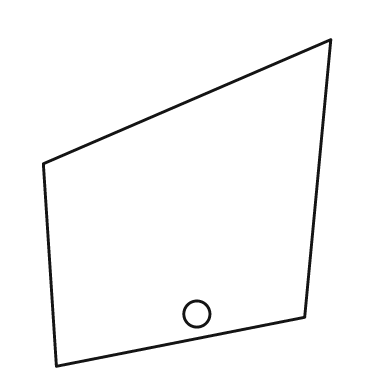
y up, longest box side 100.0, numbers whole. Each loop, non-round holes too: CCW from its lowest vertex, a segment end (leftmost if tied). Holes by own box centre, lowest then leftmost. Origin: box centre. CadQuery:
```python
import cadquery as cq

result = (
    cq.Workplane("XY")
    .moveTo(-40.0, -50.0)
    .lineTo(36.0, -35.0)
    .lineTo(44.0, 50.0)
    .lineTo(-44.0, 12.0)
    .close()
    .moveTo(3.0, -34.0)
    .circle(4.0)
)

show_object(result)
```